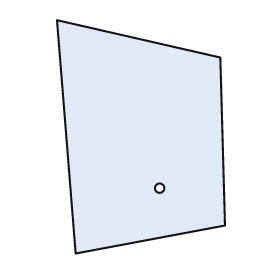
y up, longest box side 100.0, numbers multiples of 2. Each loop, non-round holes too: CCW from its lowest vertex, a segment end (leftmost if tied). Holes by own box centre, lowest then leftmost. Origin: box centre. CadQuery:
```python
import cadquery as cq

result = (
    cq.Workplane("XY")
    .moveTo(-28.0, -50.0)
    .lineTo(36.0, -38.0)
    .lineTo(34.0, 34.0)
    .lineTo(-36.0, 50.0)
    .close()
    .moveTo(8.0, -22.0)
    .circle(2.0)
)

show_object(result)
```